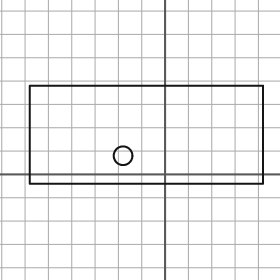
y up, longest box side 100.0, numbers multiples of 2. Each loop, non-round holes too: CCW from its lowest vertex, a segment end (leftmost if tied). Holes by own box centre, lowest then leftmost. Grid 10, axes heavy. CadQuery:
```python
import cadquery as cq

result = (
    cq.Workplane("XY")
    .moveTo(-58.0, -4.0)
    .lineTo(42.0, -4.0)
    .lineTo(42.0, 38.0)
    .lineTo(-58.0, 38.0)
    .close()
    .moveTo(-18.0, 8.0)
    .circle(4.0)
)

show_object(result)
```